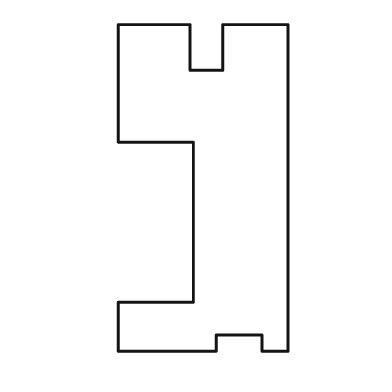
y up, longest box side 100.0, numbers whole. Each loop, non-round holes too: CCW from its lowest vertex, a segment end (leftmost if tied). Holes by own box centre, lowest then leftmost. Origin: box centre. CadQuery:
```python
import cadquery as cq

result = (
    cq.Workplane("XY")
    .moveTo(-26.0, -50.0)
    .lineTo(4.0, -50.0)
    .lineTo(4.0, -45.0)
    .lineTo(18.0, -45.0)
    .lineTo(18.0, -50.0)
    .lineTo(26.0, -50.0)
    .lineTo(26.0, 50.0)
    .lineTo(6.0, 50.0)
    .lineTo(6.0, 36.0)
    .lineTo(-4.0, 36.0)
    .lineTo(-4.0, 50.0)
    .lineTo(-26.0, 50.0)
    .lineTo(-26.0, 14.0)
    .lineTo(-3.0, 14.0)
    .lineTo(-3.0, -35.0)
    .lineTo(-26.0, -35.0)
    .close()
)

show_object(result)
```